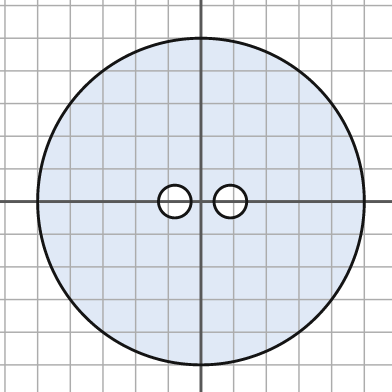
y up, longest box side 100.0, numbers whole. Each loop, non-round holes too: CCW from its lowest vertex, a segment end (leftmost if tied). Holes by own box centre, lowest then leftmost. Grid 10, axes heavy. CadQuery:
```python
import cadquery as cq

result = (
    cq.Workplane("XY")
    .moveTo(0.0, 0.0)
    .circle(50.0)
    .moveTo(-8.0, 0.0)
    .circle(5.0)
    .moveTo(9.0, 0.0)
    .circle(5.0)
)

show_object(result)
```